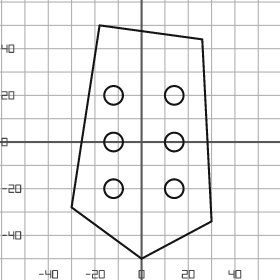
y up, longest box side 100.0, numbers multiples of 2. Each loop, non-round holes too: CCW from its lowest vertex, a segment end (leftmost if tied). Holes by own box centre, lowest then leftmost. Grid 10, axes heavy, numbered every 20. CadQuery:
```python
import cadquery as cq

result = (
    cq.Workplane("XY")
    .moveTo(0.0, -50.0)
    .lineTo(30.0, -34.0)
    .lineTo(26.0, 44.0)
    .lineTo(-18.0, 50.0)
    .lineTo(-30.0, -28.0)
    .close()
    .moveTo(-12.0, -20.0)
    .circle(4.0)
    .moveTo(14.0, -20.0)
    .circle(4.0)
    .moveTo(-12.0, 0.0)
    .circle(4.0)
    .moveTo(14.0, 0.0)
    .circle(4.0)
    .moveTo(-12.0, 20.0)
    .circle(4.0)
    .moveTo(14.0, 20.0)
    .circle(4.0)
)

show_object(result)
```